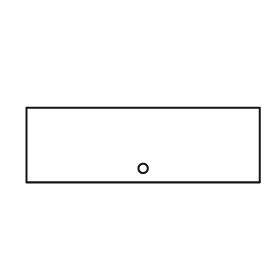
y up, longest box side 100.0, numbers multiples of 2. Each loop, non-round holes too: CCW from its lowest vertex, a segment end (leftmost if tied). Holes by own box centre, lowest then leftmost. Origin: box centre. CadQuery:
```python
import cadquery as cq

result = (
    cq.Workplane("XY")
    .moveTo(-50.0, -16.0)
    .lineTo(50.0, -16.0)
    .lineTo(50.0, 16.0)
    .lineTo(-50.0, 16.0)
    .close()
    .moveTo(0.0, -10.0)
    .circle(2.0)
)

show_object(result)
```